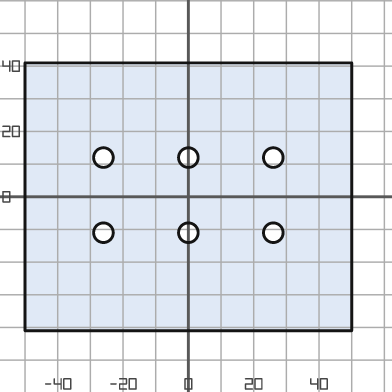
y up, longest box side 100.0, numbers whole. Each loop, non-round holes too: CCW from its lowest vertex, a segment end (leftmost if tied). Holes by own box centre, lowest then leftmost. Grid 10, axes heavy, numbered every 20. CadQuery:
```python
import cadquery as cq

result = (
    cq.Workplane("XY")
    .moveTo(-50.0, -41.0)
    .lineTo(50.0, -41.0)
    .lineTo(50.0, 41.0)
    .lineTo(-50.0, 41.0)
    .close()
    .moveTo(-26.0, -11.0)
    .circle(3.0)
    .moveTo(0.0, -11.0)
    .circle(3.0)
    .moveTo(26.0, -11.0)
    .circle(3.0)
    .moveTo(-26.0, 12.0)
    .circle(3.0)
    .moveTo(0.0, 12.0)
    .circle(3.0)
    .moveTo(26.0, 12.0)
    .circle(3.0)
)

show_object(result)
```